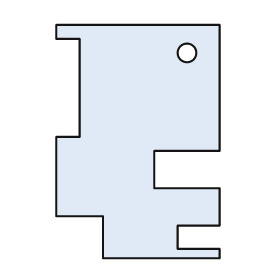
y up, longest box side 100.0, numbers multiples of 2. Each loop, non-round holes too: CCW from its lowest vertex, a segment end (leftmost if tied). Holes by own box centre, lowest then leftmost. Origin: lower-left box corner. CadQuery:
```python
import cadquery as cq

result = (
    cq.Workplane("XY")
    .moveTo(20.0, 0.0)
    .lineTo(70.0, 0.0)
    .lineTo(70.0, 4.0)
    .lineTo(52.0, 4.0)
    .lineTo(52.0, 14.0)
    .lineTo(70.0, 14.0)
    .lineTo(70.0, 30.0)
    .lineTo(42.0, 30.0)
    .lineTo(42.0, 46.0)
    .lineTo(70.0, 46.0)
    .lineTo(70.0, 100.0)
    .lineTo(0.0, 100.0)
    .lineTo(0.0, 94.0)
    .lineTo(10.0, 94.0)
    .lineTo(10.0, 52.0)
    .lineTo(0.0, 52.0)
    .lineTo(0.0, 18.0)
    .lineTo(20.0, 18.0)
    .close()
    .moveTo(56.0, 88.0)
    .circle(4.0)
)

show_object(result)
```